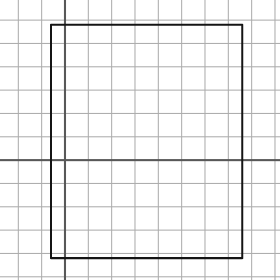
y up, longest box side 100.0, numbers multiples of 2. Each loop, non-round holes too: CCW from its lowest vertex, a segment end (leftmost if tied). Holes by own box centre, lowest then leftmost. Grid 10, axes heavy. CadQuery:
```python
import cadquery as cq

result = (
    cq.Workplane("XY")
    .moveTo(-6.0, -42.0)
    .lineTo(76.0, -42.0)
    .lineTo(76.0, 58.0)
    .lineTo(-6.0, 58.0)
    .close()
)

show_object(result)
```